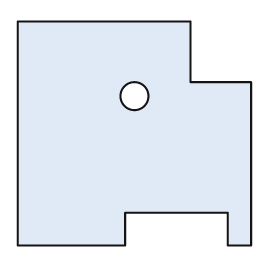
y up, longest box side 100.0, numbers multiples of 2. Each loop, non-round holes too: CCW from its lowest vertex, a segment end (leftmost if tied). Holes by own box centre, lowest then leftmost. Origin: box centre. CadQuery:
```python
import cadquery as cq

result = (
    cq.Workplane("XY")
    .moveTo(-50.0, -48.0)
    .lineTo(-4.0, -48.0)
    .lineTo(-4.0, -34.0)
    .lineTo(40.0, -34.0)
    .lineTo(40.0, -48.0)
    .lineTo(50.0, -48.0)
    .lineTo(50.0, 22.0)
    .lineTo(24.0, 22.0)
    .lineTo(24.0, 48.0)
    .lineTo(-50.0, 48.0)
    .close()
    .moveTo(0.0, 16.0)
    .circle(6.0)
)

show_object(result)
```